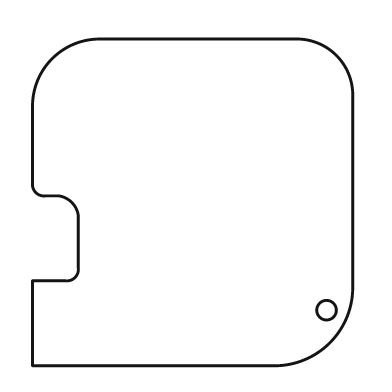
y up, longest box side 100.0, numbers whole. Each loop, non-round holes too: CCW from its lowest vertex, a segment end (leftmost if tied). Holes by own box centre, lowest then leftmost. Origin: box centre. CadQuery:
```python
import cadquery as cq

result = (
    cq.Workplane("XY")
    .moveTo(-49.0, -50.0)
    .lineTo(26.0, -50.0)
    .threePointArc((42.0, -43.0), (49.0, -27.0))
    .lineTo(49.0, 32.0)
    .threePointArc((44.0, 45.0), (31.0, 50.0))
    .lineTo(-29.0, 50.0)
    .threePointArc((-43.0, 44.0), (-49.0, 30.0))
    .lineTo(-49.0, 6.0)
    .threePointArc((-48.0, 3.0), (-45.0, 2.0))
    .lineTo(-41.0, 2.0)
    .threePointArc((-37.0, 0.0), (-35.0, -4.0))
    .lineTo(-35.0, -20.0)
    .threePointArc((-36.0, -23.0), (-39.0, -24.0))
    .lineTo(-49.0, -24.0)
    .close()
    .moveTo(41.0, -33.0)
    .circle(3.0)
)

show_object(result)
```